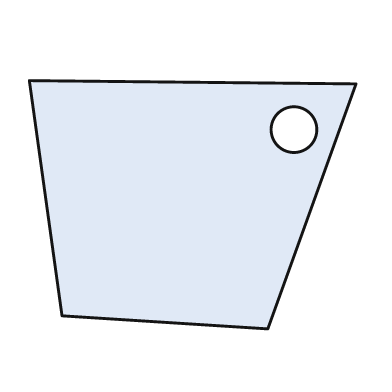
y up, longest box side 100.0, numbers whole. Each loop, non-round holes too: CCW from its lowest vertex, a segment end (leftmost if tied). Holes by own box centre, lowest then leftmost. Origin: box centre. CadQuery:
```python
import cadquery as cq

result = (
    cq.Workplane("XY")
    .moveTo(23.0, -38.0)
    .lineTo(50.0, 37.0)
    .lineTo(-50.0, 38.0)
    .lineTo(-40.0, -34.0)
    .close()
    .moveTo(31.0, 23.0)
    .circle(7.0)
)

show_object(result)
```